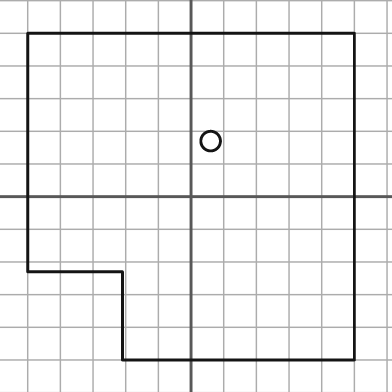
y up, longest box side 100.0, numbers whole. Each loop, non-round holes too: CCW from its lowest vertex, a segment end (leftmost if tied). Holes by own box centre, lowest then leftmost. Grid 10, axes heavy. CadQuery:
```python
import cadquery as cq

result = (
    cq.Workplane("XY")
    .moveTo(-21.0, -50.0)
    .lineTo(50.0, -50.0)
    .lineTo(50.0, 50.0)
    .lineTo(-50.0, 50.0)
    .lineTo(-50.0, -23.0)
    .lineTo(-21.0, -23.0)
    .close()
    .moveTo(6.0, 17.0)
    .circle(3.0)
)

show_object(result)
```